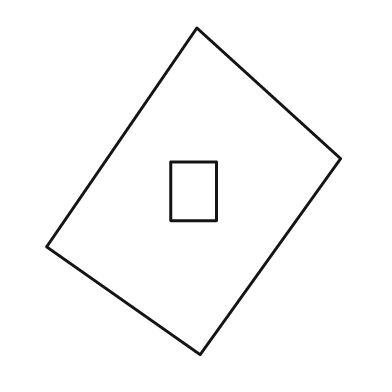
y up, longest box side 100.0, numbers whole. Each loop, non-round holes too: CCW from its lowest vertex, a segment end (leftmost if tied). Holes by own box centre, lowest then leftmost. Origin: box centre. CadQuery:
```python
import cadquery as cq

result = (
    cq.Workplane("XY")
    .moveTo(2.0, -50.0)
    .lineTo(45.0, 10.0)
    .lineTo(1.0, 50.0)
    .lineTo(-45.0, -17.0)
    .close()
    .moveTo(-7.0, -9.0)
    .lineTo(7.0, -9.0)
    .lineTo(7.0, 9.0)
    .lineTo(-7.0, 9.0)
    .close()
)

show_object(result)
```